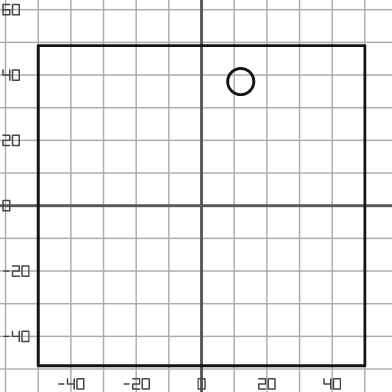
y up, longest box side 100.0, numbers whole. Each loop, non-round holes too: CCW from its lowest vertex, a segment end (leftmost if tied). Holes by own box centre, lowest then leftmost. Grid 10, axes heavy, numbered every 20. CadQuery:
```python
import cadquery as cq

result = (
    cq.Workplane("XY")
    .moveTo(-50.0, -49.0)
    .lineTo(50.0, -49.0)
    .lineTo(50.0, 49.0)
    .lineTo(-50.0, 49.0)
    .close()
    .moveTo(12.0, 38.0)
    .circle(4.0)
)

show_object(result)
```